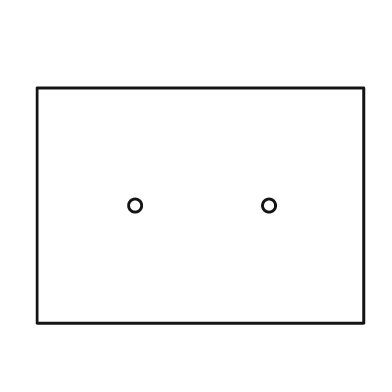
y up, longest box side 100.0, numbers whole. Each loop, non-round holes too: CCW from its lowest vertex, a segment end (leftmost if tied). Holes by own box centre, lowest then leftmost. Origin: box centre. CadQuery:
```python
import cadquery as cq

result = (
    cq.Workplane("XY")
    .moveTo(-50.0, -36.0)
    .lineTo(50.0, -36.0)
    .lineTo(50.0, 36.0)
    .lineTo(-50.0, 36.0)
    .close()
    .moveTo(-20.0, 0.0)
    .circle(2.0)
    .moveTo(21.0, 0.0)
    .circle(2.0)
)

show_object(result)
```